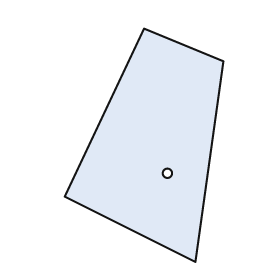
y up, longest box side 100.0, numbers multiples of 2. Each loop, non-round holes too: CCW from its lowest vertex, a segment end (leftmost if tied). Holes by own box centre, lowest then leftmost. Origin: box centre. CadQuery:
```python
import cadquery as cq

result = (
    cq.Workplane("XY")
    .moveTo(22.0, -50.0)
    .lineTo(34.0, 36.0)
    .lineTo(0.0, 50.0)
    .lineTo(-34.0, -22.0)
    .close()
    .moveTo(10.0, -12.0)
    .circle(2.0)
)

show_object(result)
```